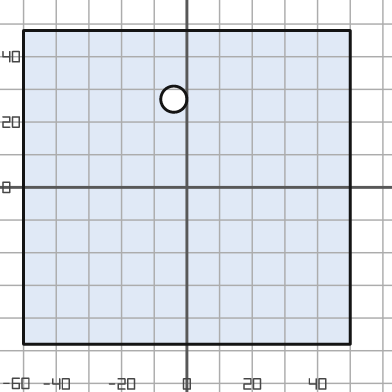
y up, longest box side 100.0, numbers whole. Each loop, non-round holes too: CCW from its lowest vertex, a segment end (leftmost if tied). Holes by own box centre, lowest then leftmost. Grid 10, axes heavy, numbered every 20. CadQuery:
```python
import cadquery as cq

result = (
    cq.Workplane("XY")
    .moveTo(-50.0, -48.0)
    .lineTo(50.0, -48.0)
    .lineTo(50.0, 48.0)
    .lineTo(-50.0, 48.0)
    .close()
    .moveTo(-4.0, 27.0)
    .circle(4.0)
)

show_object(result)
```